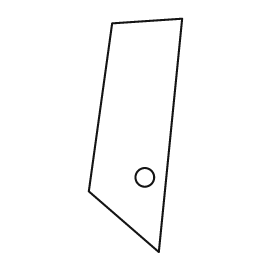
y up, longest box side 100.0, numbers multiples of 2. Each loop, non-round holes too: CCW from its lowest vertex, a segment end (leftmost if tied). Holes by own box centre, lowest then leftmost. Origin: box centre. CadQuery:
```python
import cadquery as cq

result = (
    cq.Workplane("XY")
    .moveTo(10.0, -50.0)
    .lineTo(20.0, 50.0)
    .lineTo(-10.0, 48.0)
    .lineTo(-20.0, -24.0)
    .close()
    .moveTo(4.0, -18.0)
    .circle(4.0)
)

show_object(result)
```